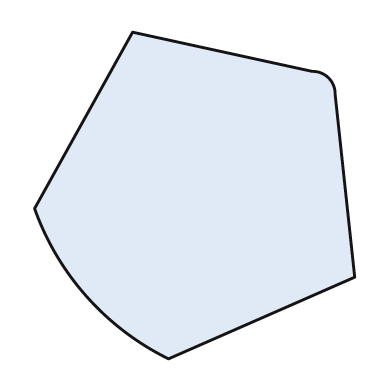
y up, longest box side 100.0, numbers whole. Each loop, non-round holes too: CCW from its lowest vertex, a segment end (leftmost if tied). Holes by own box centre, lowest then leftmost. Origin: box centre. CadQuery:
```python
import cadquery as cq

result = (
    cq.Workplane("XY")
    .moveTo(-8.0, -50.0)
    .lineTo(49.0, -25.0)
    .lineTo(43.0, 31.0)
    .threePointArc((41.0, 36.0), (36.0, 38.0))
    .lineTo(-19.0, 50.0)
    .lineTo(-49.0, -4.0)
    .threePointArc((-33.0, -31.0), (-8.0, -50.0))
    .close()
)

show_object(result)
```